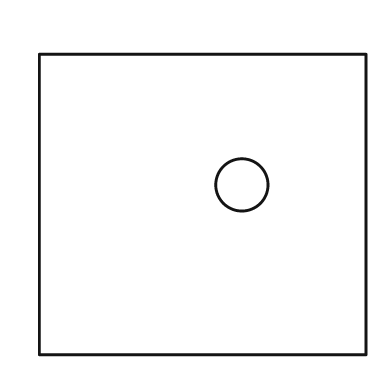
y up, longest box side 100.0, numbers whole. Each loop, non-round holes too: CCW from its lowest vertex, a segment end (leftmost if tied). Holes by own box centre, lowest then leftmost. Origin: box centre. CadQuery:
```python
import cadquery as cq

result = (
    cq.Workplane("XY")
    .moveTo(-50.0, -46.0)
    .lineTo(50.0, -46.0)
    .lineTo(50.0, 46.0)
    .lineTo(-50.0, 46.0)
    .close()
    .moveTo(12.0, 6.0)
    .circle(8.0)
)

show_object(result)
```